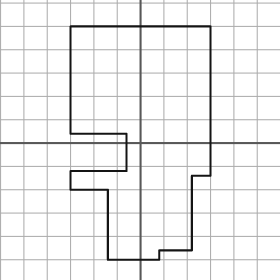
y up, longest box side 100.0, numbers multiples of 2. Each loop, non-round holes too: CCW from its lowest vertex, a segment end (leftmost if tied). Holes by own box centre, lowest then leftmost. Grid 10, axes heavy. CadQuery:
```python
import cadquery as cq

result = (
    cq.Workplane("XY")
    .moveTo(-14.0, -50.0)
    .lineTo(8.0, -50.0)
    .lineTo(8.0, -46.0)
    .lineTo(22.0, -46.0)
    .lineTo(22.0, -14.0)
    .lineTo(30.0, -14.0)
    .lineTo(30.0, 50.0)
    .lineTo(-30.0, 50.0)
    .lineTo(-30.0, 4.0)
    .lineTo(-6.0, 4.0)
    .lineTo(-6.0, -12.0)
    .lineTo(-30.0, -12.0)
    .lineTo(-30.0, -20.0)
    .lineTo(-14.0, -20.0)
    .close()
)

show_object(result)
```